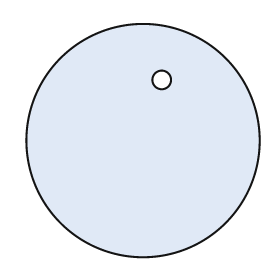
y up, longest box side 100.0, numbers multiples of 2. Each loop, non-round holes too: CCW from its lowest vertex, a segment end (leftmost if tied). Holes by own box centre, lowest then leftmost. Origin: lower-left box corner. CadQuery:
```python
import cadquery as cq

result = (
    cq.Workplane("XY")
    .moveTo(50.0, 50.0)
    .circle(50.0)
    .moveTo(58.0, 76.0)
    .circle(4.0)
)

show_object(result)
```